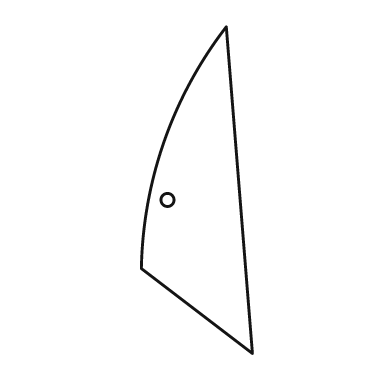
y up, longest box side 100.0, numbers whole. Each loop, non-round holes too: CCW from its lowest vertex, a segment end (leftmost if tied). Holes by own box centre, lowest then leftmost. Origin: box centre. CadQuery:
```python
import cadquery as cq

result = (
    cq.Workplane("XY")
    .moveTo(17.0, -50.0)
    .lineTo(9.0, 50.0)
    .threePointArc((-10.0, 15.0), (-17.0, -24.0))
    .close()
    .moveTo(-9.0, -3.0)
    .circle(2.0)
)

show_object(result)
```